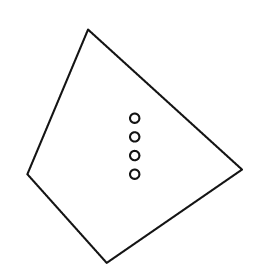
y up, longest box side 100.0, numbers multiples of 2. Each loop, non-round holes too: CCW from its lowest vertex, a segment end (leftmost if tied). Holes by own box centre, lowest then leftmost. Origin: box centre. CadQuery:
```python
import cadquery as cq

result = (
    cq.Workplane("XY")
    .moveTo(-12.0, -50.0)
    .lineTo(46.0, -10.0)
    .lineTo(-20.0, 50.0)
    .lineTo(-46.0, -12.0)
    .close()
    .moveTo(0.0, -12.0)
    .circle(2.0)
    .moveTo(0.0, -4.0)
    .circle(2.0)
    .moveTo(0.0, 4.0)
    .circle(2.0)
    .moveTo(0.0, 12.0)
    .circle(2.0)
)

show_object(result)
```